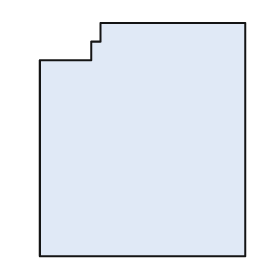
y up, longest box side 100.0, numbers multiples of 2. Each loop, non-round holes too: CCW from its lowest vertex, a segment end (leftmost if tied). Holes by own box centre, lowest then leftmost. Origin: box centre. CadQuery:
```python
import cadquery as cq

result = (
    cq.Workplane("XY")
    .moveTo(-44.0, -50.0)
    .lineTo(44.0, -50.0)
    .lineTo(44.0, 50.0)
    .lineTo(-18.0, 50.0)
    .lineTo(-18.0, 42.0)
    .lineTo(-22.0, 42.0)
    .lineTo(-22.0, 34.0)
    .lineTo(-44.0, 34.0)
    .close()
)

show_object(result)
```